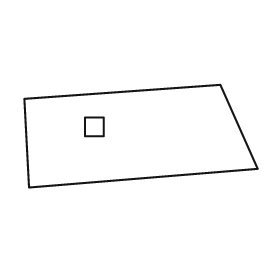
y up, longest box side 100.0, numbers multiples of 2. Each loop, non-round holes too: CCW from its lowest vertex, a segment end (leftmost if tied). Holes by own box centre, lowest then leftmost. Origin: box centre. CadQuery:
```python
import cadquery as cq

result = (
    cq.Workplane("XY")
    .moveTo(-48.0, -22.0)
    .lineTo(50.0, -14.0)
    .lineTo(34.0, 22.0)
    .lineTo(-50.0, 16.0)
    .close()
    .moveTo(-24.0, 0.0)
    .lineTo(-16.0, 0.0)
    .lineTo(-16.0, 8.0)
    .lineTo(-24.0, 8.0)
    .close()
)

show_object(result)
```